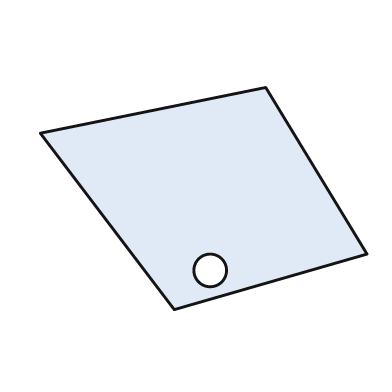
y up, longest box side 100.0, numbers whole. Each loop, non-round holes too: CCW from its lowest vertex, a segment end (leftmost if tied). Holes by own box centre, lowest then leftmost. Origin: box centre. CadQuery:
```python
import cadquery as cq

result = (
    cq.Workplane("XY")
    .moveTo(-9.0, -34.0)
    .lineTo(50.0, -17.0)
    .lineTo(19.0, 34.0)
    .lineTo(-50.0, 20.0)
    .close()
    .moveTo(2.0, -22.0)
    .circle(5.0)
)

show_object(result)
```